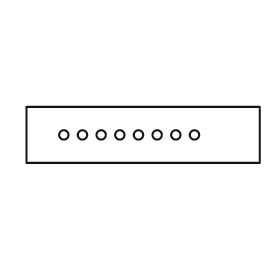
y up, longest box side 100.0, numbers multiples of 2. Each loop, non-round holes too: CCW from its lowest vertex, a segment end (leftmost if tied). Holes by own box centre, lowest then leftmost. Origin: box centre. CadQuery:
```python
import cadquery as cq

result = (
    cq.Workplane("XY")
    .moveTo(-50.0, -12.0)
    .lineTo(50.0, -12.0)
    .lineTo(50.0, 12.0)
    .lineTo(-50.0, 12.0)
    .close()
    .moveTo(-34.0, 0.0)
    .circle(2.0)
    .moveTo(-26.0, 0.0)
    .circle(2.0)
    .moveTo(-18.0, 0.0)
    .circle(2.0)
    .moveTo(-10.0, 0.0)
    .circle(2.0)
    .moveTo(-2.0, 0.0)
    .circle(2.0)
    .moveTo(6.0, 0.0)
    .circle(2.0)
    .moveTo(14.0, 0.0)
    .circle(2.0)
    .moveTo(22.0, 0.0)
    .circle(2.0)
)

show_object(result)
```